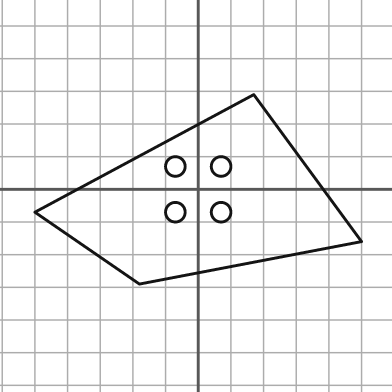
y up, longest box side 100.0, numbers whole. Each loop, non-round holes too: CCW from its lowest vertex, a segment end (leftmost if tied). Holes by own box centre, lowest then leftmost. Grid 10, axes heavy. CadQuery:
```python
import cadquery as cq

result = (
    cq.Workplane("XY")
    .moveTo(-18.0, -29.0)
    .lineTo(50.0, -16.0)
    .lineTo(17.0, 29.0)
    .lineTo(-50.0, -7.0)
    .close()
    .moveTo(-7.0, -7.0)
    .circle(3.0)
    .moveTo(7.0, -7.0)
    .circle(3.0)
    .moveTo(-7.0, 7.0)
    .circle(3.0)
    .moveTo(7.0, 7.0)
    .circle(3.0)
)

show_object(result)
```